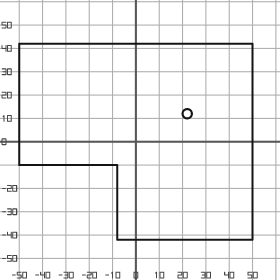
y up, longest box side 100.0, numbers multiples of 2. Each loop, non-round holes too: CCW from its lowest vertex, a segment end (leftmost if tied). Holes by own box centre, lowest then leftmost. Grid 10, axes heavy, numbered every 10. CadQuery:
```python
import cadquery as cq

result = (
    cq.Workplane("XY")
    .moveTo(-8.0, -42.0)
    .lineTo(50.0, -42.0)
    .lineTo(50.0, 42.0)
    .lineTo(-50.0, 42.0)
    .lineTo(-50.0, -10.0)
    .lineTo(-8.0, -10.0)
    .close()
    .moveTo(22.0, 12.0)
    .circle(2.0)
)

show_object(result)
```